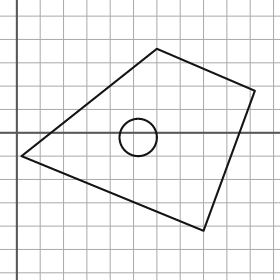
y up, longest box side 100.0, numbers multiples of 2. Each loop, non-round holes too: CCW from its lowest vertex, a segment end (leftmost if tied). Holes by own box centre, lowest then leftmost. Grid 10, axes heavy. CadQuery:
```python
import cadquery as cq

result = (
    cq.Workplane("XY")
    .moveTo(80.0, -42.0)
    .lineTo(102.0, 18.0)
    .lineTo(60.0, 36.0)
    .lineTo(2.0, -10.0)
    .close()
    .moveTo(52.0, -2.0)
    .circle(8.0)
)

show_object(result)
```